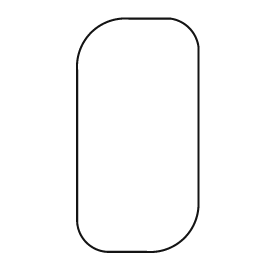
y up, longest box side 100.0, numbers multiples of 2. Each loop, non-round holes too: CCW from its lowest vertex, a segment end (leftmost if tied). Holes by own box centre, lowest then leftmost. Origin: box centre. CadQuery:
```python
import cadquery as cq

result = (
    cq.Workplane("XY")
    .moveTo(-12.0, -50.0)
    .lineTo(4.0, -50.0)
    .threePointArc((20.0, -44.0), (26.0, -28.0))
    .lineTo(26.0, 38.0)
    .threePointArc((22.0, 46.0), (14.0, 50.0))
    .lineTo(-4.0, 50.0)
    .threePointArc((-20.0, 44.0), (-26.0, 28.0))
    .lineTo(-26.0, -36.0)
    .threePointArc((-22.0, -46.0), (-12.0, -50.0))
    .close()
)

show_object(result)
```